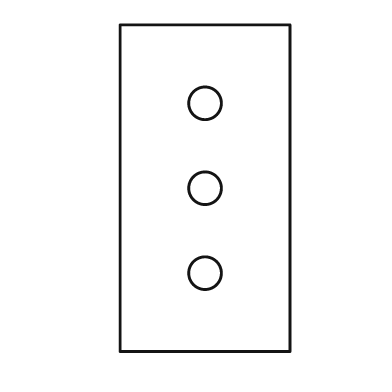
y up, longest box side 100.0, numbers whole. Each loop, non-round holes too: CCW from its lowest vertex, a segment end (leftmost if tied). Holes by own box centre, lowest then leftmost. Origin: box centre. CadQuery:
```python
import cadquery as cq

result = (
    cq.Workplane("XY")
    .moveTo(-26.0, -50.0)
    .lineTo(26.0, -50.0)
    .lineTo(26.0, 50.0)
    .lineTo(-26.0, 50.0)
    .close()
    .moveTo(0.0, -26.0)
    .circle(5.0)
    .moveTo(0.0, 0.0)
    .circle(5.0)
    .moveTo(0.0, 26.0)
    .circle(5.0)
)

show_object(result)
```